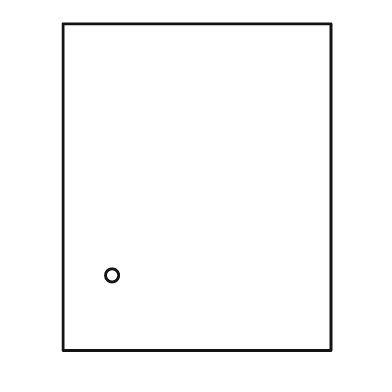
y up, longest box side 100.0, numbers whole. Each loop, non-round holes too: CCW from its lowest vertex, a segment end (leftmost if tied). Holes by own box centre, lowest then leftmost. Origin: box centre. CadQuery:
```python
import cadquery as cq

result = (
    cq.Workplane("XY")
    .moveTo(-41.0, -50.0)
    .lineTo(41.0, -50.0)
    .lineTo(41.0, 50.0)
    .lineTo(-41.0, 50.0)
    .close()
    .moveTo(-26.0, -27.0)
    .circle(2.0)
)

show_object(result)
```